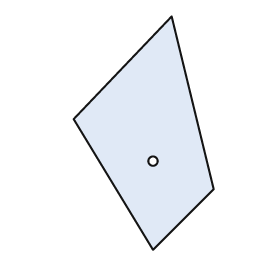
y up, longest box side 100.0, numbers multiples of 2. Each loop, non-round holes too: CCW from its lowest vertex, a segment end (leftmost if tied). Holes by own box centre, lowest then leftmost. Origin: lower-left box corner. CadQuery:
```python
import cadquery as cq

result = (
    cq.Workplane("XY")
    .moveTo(34.0, 0.0)
    .lineTo(60.0, 26.0)
    .lineTo(42.0, 100.0)
    .lineTo(0.0, 56.0)
    .close()
    .moveTo(34.0, 38.0)
    .circle(2.0)
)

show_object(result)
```